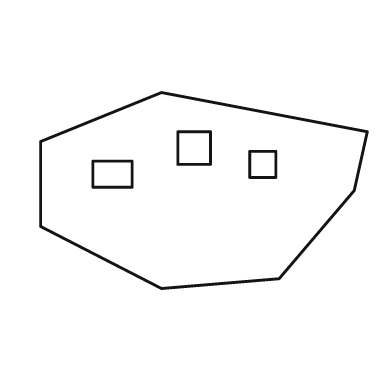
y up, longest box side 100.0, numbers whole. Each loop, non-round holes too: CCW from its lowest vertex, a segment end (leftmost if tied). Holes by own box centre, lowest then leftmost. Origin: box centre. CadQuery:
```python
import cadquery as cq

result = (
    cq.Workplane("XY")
    .moveTo(-13.0, -30.0)
    .lineTo(23.0, -27.0)
    .lineTo(46.0, 0.0)
    .lineTo(50.0, 18.0)
    .lineTo(-13.0, 30.0)
    .lineTo(-50.0, 15.0)
    .lineTo(-50.0, -11.0)
    .close()
    .moveTo(-34.0, 1.0)
    .lineTo(-22.0, 1.0)
    .lineTo(-22.0, 9.0)
    .lineTo(-34.0, 9.0)
    .close()
    .moveTo(14.0, 4.0)
    .lineTo(22.0, 4.0)
    .lineTo(22.0, 12.0)
    .lineTo(14.0, 12.0)
    .close()
    .moveTo(-8.0, 8.0)
    .lineTo(2.0, 8.0)
    .lineTo(2.0, 18.0)
    .lineTo(-8.0, 18.0)
    .close()
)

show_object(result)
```